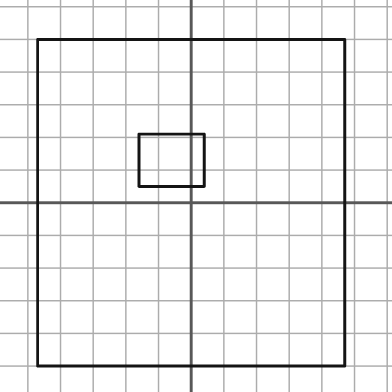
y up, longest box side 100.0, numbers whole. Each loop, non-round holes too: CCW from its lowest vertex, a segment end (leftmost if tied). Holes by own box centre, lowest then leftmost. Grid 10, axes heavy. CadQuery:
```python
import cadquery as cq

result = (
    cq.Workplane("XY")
    .moveTo(-47.0, -50.0)
    .lineTo(47.0, -50.0)
    .lineTo(47.0, 50.0)
    .lineTo(-47.0, 50.0)
    .close()
    .moveTo(-16.0, 5.0)
    .lineTo(4.0, 5.0)
    .lineTo(4.0, 21.0)
    .lineTo(-16.0, 21.0)
    .close()
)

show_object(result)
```